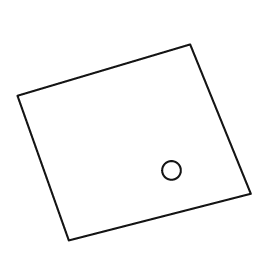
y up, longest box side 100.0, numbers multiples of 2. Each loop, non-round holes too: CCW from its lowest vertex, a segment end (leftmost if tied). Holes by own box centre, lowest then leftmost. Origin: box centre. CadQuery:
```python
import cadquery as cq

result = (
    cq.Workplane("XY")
    .moveTo(-28.0, -42.0)
    .lineTo(50.0, -22.0)
    .lineTo(24.0, 42.0)
    .lineTo(-50.0, 20.0)
    .close()
    .moveTo(16.0, -12.0)
    .circle(4.0)
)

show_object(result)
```